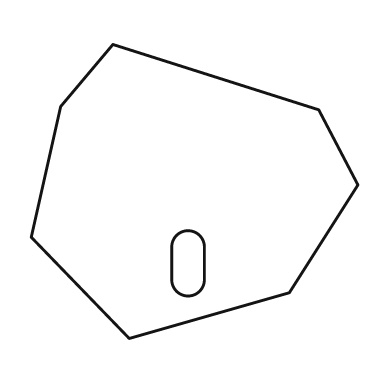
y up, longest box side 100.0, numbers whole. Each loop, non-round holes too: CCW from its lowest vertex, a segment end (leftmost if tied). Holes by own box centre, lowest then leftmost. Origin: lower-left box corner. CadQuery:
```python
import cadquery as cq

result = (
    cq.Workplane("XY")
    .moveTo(30.0, 0.0)
    .lineTo(79.0, 14.0)
    .lineTo(100.0, 47.0)
    .lineTo(88.0, 70.0)
    .lineTo(25.0, 90.0)
    .lineTo(9.0, 71.0)
    .lineTo(0.0, 31.0)
    .close()
    .moveTo(43.0, 18.0)
    .threePointArc((48.0, 13.0), (53.0, 18.0))
    .lineTo(53.0, 28.0)
    .threePointArc((48.0, 33.0), (43.0, 28.0))
    .close()
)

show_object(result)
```